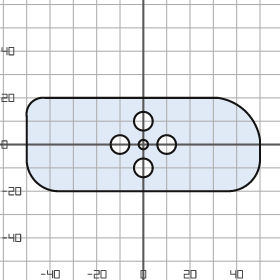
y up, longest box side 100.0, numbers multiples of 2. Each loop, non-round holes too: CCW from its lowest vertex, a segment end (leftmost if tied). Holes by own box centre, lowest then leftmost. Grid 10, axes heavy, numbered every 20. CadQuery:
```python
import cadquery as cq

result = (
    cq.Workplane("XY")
    .moveTo(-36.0, -20.0)
    .lineTo(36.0, -20.0)
    .threePointArc((46.0, -16.0), (50.0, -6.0))
    .lineTo(50.0, 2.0)
    .threePointArc((44.0, 14.0), (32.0, 20.0))
    .lineTo(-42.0, 20.0)
    .threePointArc((-48.0, 18.0), (-50.0, 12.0))
    .lineTo(-50.0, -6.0)
    .threePointArc((-46.0, -16.0), (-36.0, -20.0))
    .close()
    .moveTo(0.0, -10.0)
    .circle(4.0)
    .moveTo(-10.0, 0.0)
    .circle(4.0)
    .moveTo(0.0, 0.0)
    .circle(2.0)
    .moveTo(10.0, 0.0)
    .circle(4.0)
    .moveTo(0.0, 10.0)
    .circle(4.0)
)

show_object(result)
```